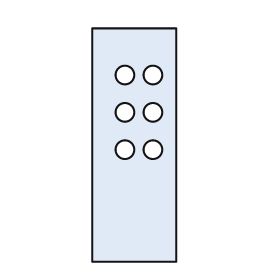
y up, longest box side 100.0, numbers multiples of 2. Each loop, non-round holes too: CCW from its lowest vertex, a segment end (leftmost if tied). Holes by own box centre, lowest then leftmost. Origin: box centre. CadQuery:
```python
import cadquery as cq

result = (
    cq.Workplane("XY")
    .moveTo(-18.0, -50.0)
    .lineTo(18.0, -50.0)
    .lineTo(18.0, 50.0)
    .lineTo(-18.0, 50.0)
    .close()
    .moveTo(-4.0, -2.0)
    .circle(4.0)
    .moveTo(8.0, -2.0)
    .circle(4.0)
    .moveTo(-4.0, 14.0)
    .circle(4.0)
    .moveTo(8.0, 14.0)
    .circle(4.0)
    .moveTo(-4.0, 30.0)
    .circle(4.0)
    .moveTo(8.0, 30.0)
    .circle(4.0)
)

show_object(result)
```